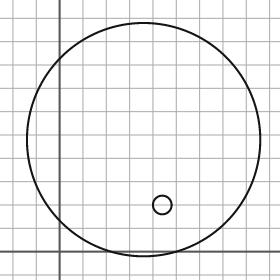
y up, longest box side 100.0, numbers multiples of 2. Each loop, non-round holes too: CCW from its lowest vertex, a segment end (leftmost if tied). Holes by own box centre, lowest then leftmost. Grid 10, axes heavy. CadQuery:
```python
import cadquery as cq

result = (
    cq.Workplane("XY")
    .moveTo(36.0, 48.0)
    .circle(50.0)
    .moveTo(44.0, 20.0)
    .circle(4.0)
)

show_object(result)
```